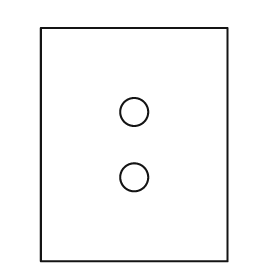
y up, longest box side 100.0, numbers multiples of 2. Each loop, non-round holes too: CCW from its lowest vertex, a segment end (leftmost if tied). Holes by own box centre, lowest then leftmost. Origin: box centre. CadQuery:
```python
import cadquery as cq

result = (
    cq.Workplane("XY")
    .moveTo(-40.0, -50.0)
    .lineTo(40.0, -50.0)
    .lineTo(40.0, 50.0)
    .lineTo(-40.0, 50.0)
    .close()
    .moveTo(0.0, -14.0)
    .circle(6.0)
    .moveTo(0.0, 14.0)
    .circle(6.0)
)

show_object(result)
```